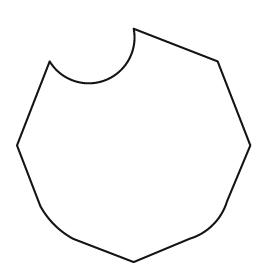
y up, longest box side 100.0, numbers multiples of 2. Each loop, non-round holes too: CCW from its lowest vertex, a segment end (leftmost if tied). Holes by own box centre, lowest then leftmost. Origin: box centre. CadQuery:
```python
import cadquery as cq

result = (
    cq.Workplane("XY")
    .moveTo(0.0, -50.0)
    .lineTo(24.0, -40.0)
    .threePointArc((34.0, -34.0), (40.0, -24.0))
    .lineTo(50.0, 0.0)
    .lineTo(36.0, 36.0)
    .lineTo(0.0, 50.0)
    .threePointArc((-12.0, 28.0), (-36.0, 36.0))
    .lineTo(-50.0, 0.0)
    .lineTo(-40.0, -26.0)
    .threePointArc((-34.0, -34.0), (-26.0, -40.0))
    .close()
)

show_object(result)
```